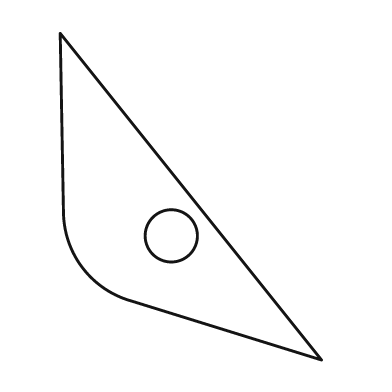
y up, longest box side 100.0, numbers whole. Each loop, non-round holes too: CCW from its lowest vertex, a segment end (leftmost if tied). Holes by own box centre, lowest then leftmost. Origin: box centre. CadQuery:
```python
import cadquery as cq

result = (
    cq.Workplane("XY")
    .moveTo(40.0, -50.0)
    .lineTo(-40.0, 50.0)
    .lineTo(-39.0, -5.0)
    .threePointArc((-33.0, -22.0), (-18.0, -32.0))
    .close()
    .moveTo(-6.0, -12.0)
    .circle(8.0)
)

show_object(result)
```